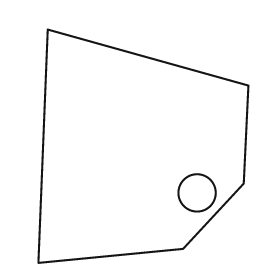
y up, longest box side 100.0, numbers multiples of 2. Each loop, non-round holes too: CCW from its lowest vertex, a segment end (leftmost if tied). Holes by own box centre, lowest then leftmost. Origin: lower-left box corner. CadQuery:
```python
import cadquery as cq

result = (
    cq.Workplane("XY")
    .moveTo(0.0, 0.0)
    .lineTo(62.0, 6.0)
    .lineTo(88.0, 34.0)
    .lineTo(90.0, 76.0)
    .lineTo(4.0, 100.0)
    .close()
    .moveTo(68.0, 30.0)
    .circle(8.0)
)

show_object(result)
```